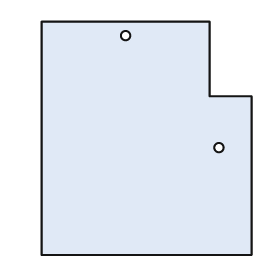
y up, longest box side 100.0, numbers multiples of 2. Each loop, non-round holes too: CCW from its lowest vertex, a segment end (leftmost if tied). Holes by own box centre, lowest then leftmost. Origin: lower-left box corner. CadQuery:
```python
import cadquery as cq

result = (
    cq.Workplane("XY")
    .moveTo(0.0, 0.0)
    .lineTo(90.0, 0.0)
    .lineTo(90.0, 68.0)
    .lineTo(72.0, 68.0)
    .lineTo(72.0, 100.0)
    .lineTo(0.0, 100.0)
    .close()
    .moveTo(76.0, 46.0)
    .circle(2.0)
    .moveTo(36.0, 94.0)
    .circle(2.0)
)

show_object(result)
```